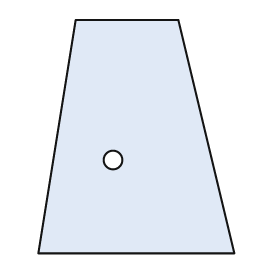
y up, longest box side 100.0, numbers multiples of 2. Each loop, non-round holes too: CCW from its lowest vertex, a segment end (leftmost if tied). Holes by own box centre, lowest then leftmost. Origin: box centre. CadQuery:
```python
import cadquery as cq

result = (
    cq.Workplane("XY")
    .moveTo(-42.0, -50.0)
    .lineTo(42.0, -50.0)
    .lineTo(18.0, 50.0)
    .lineTo(-26.0, 50.0)
    .close()
    .moveTo(-10.0, -10.0)
    .circle(4.0)
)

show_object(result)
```